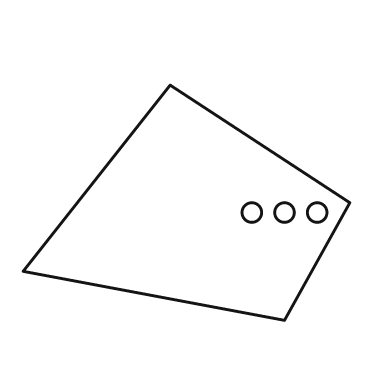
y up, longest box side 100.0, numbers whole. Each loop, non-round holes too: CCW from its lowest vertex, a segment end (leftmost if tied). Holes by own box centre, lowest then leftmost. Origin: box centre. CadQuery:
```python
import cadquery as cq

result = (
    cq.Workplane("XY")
    .moveTo(30.0, -36.0)
    .lineTo(50.0, 0.0)
    .lineTo(-5.0, 36.0)
    .lineTo(-50.0, -21.0)
    .close()
    .moveTo(20.0, -3.0)
    .circle(3.0)
    .moveTo(30.0, -3.0)
    .circle(3.0)
    .moveTo(40.0, -3.0)
    .circle(3.0)
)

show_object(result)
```